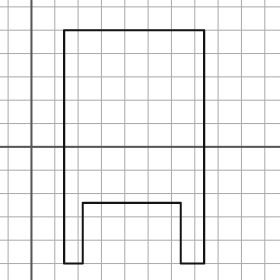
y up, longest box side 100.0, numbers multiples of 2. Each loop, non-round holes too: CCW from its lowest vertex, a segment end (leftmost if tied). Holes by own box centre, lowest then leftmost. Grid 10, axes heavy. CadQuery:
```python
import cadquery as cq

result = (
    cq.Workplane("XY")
    .moveTo(14.0, -50.0)
    .lineTo(22.0, -50.0)
    .lineTo(22.0, -24.0)
    .lineTo(64.0, -24.0)
    .lineTo(64.0, -50.0)
    .lineTo(74.0, -50.0)
    .lineTo(74.0, 50.0)
    .lineTo(14.0, 50.0)
    .close()
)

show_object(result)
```